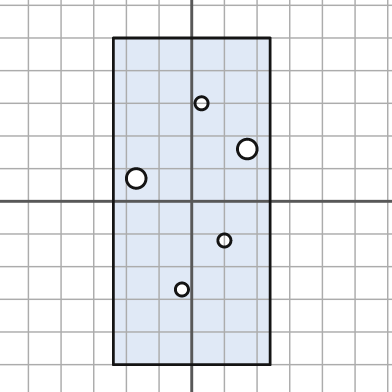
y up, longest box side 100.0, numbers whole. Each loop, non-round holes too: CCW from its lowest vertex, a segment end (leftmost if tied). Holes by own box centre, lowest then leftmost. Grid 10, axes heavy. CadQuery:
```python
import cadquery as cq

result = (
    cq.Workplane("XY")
    .moveTo(-24.0, -50.0)
    .lineTo(24.0, -50.0)
    .lineTo(24.0, 50.0)
    .lineTo(-24.0, 50.0)
    .close()
    .moveTo(-3.0, -27.0)
    .circle(2.0)
    .moveTo(10.0, -12.0)
    .circle(2.0)
    .moveTo(-17.0, 7.0)
    .circle(3.0)
    .moveTo(17.0, 16.0)
    .circle(3.0)
    .moveTo(3.0, 30.0)
    .circle(2.0)
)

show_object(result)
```